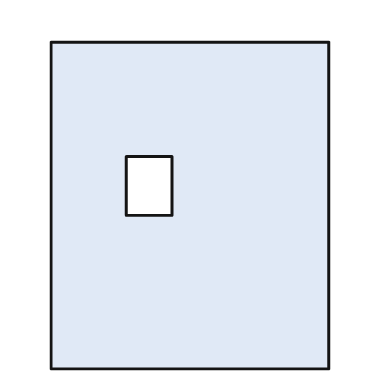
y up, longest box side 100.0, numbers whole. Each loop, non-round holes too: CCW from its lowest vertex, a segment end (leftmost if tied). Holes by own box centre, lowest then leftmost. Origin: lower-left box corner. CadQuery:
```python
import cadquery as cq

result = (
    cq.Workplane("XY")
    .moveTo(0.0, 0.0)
    .lineTo(85.0, 0.0)
    .lineTo(85.0, 100.0)
    .lineTo(0.0, 100.0)
    .close()
    .moveTo(23.0, 47.0)
    .lineTo(37.0, 47.0)
    .lineTo(37.0, 65.0)
    .lineTo(23.0, 65.0)
    .close()
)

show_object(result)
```